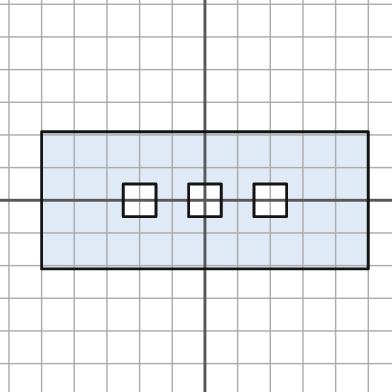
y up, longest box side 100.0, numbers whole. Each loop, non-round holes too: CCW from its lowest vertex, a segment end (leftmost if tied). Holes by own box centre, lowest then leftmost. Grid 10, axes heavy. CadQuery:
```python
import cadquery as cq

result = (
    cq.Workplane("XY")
    .moveTo(-50.0, -21.0)
    .lineTo(50.0, -21.0)
    .lineTo(50.0, 21.0)
    .lineTo(-50.0, 21.0)
    .close()
    .moveTo(-25.0, -5.0)
    .lineTo(-15.0, -5.0)
    .lineTo(-15.0, 5.0)
    .lineTo(-25.0, 5.0)
    .close()
    .moveTo(-5.0, -5.0)
    .lineTo(5.0, -5.0)
    .lineTo(5.0, 5.0)
    .lineTo(-5.0, 5.0)
    .close()
    .moveTo(15.0, -5.0)
    .lineTo(25.0, -5.0)
    .lineTo(25.0, 5.0)
    .lineTo(15.0, 5.0)
    .close()
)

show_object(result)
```